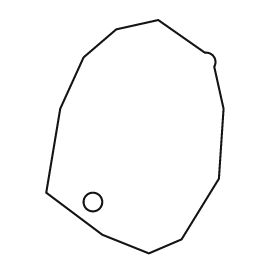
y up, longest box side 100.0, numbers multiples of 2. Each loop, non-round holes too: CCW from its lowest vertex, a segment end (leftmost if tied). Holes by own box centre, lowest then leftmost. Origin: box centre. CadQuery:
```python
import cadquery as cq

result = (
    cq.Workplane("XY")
    .moveTo(6.0, -50.0)
    .lineTo(20.0, -44.0)
    .lineTo(36.0, -18.0)
    .lineTo(38.0, 12.0)
    .lineTo(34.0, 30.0)
    .threePointArc((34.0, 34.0), (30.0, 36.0))
    .lineTo(10.0, 50.0)
    .lineTo(-8.0, 46.0)
    .lineTo(-22.0, 34.0)
    .lineTo(-32.0, 12.0)
    .lineTo(-38.0, -24.0)
    .lineTo(-14.0, -42.0)
    .close()
    .moveTo(-18.0, -28.0)
    .circle(4.0)
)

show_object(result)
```